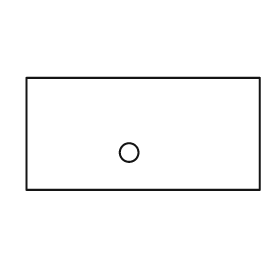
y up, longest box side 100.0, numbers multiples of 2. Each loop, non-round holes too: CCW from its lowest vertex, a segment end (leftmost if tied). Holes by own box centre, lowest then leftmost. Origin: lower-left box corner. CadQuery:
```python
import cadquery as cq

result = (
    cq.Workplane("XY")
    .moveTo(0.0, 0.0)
    .lineTo(100.0, 0.0)
    .lineTo(100.0, 48.0)
    .lineTo(0.0, 48.0)
    .close()
    .moveTo(44.0, 16.0)
    .circle(4.0)
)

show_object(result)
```